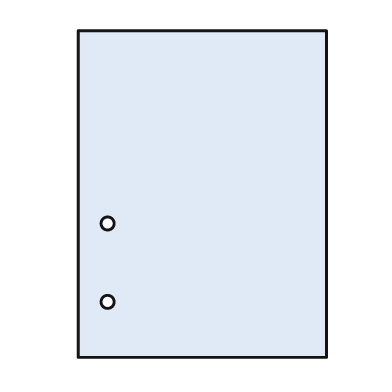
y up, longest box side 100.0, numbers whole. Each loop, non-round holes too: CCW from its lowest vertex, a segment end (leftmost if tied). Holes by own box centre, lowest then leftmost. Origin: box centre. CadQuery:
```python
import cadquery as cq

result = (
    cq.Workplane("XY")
    .moveTo(-38.0, -50.0)
    .lineTo(38.0, -50.0)
    .lineTo(38.0, 50.0)
    .lineTo(-38.0, 50.0)
    .close()
    .moveTo(-29.0, -33.0)
    .circle(2.0)
    .moveTo(-29.0, -9.0)
    .circle(2.0)
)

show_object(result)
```